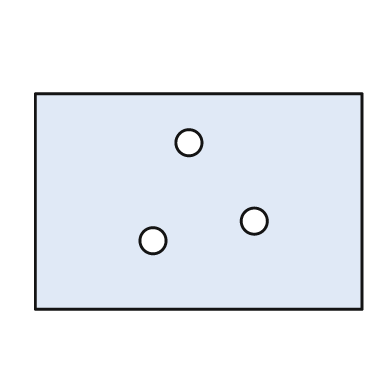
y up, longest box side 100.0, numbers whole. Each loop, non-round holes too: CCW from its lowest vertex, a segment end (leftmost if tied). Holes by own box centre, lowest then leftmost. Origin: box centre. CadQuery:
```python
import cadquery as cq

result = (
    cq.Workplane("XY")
    .moveTo(-50.0, -33.0)
    .lineTo(50.0, -33.0)
    .lineTo(50.0, 33.0)
    .lineTo(-50.0, 33.0)
    .close()
    .moveTo(-14.0, -12.0)
    .circle(4.0)
    .moveTo(17.0, -6.0)
    .circle(4.0)
    .moveTo(-3.0, 18.0)
    .circle(4.0)
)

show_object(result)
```